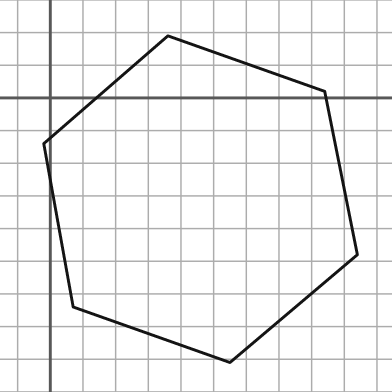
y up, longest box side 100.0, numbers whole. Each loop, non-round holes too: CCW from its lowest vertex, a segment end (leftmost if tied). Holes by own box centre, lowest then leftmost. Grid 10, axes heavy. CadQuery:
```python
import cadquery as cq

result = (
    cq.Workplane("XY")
    .moveTo(55.0, -81.0)
    .lineTo(94.0, -48.0)
    .lineTo(84.0, 2.0)
    .lineTo(36.0, 19.0)
    .lineTo(-2.0, -14.0)
    .lineTo(7.0, -64.0)
    .close()
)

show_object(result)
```